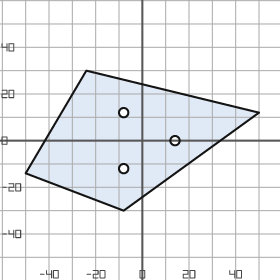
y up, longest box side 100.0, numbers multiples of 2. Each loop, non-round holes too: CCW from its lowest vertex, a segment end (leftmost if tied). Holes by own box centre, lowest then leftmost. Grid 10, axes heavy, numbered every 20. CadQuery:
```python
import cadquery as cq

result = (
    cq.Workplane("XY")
    .moveTo(-8.0, -30.0)
    .lineTo(50.0, 12.0)
    .lineTo(-24.0, 30.0)
    .lineTo(-50.0, -14.0)
    .close()
    .moveTo(-8.0, -12.0)
    .circle(2.0)
    .moveTo(14.0, 0.0)
    .circle(2.0)
    .moveTo(-8.0, 12.0)
    .circle(2.0)
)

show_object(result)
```